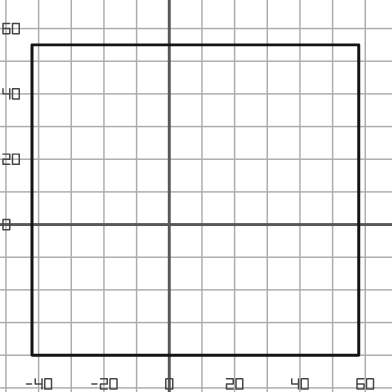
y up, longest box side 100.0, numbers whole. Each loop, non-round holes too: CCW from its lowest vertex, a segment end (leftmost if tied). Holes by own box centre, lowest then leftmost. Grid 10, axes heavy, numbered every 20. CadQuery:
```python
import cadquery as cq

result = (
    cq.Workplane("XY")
    .moveTo(-42.0, -40.0)
    .lineTo(58.0, -40.0)
    .lineTo(58.0, 55.0)
    .lineTo(-42.0, 55.0)
    .close()
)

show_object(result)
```